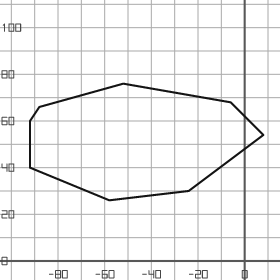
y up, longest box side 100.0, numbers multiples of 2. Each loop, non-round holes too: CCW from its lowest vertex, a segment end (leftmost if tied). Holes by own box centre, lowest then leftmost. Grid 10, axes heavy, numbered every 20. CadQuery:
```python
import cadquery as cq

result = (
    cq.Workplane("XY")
    .moveTo(-58.0, 26.0)
    .lineTo(-24.0, 30.0)
    .lineTo(8.0, 54.0)
    .lineTo(-6.0, 68.0)
    .lineTo(-52.0, 76.0)
    .lineTo(-88.0, 66.0)
    .lineTo(-92.0, 60.0)
    .lineTo(-92.0, 40.0)
    .close()
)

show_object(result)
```